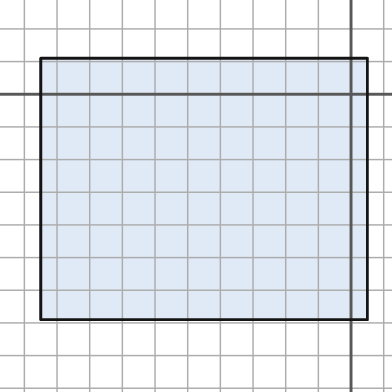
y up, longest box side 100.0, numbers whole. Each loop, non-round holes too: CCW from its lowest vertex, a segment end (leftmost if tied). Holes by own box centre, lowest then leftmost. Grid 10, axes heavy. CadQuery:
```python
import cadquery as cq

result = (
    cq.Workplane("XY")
    .moveTo(-95.0, -69.0)
    .lineTo(5.0, -69.0)
    .lineTo(5.0, 11.0)
    .lineTo(-95.0, 11.0)
    .close()
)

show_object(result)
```